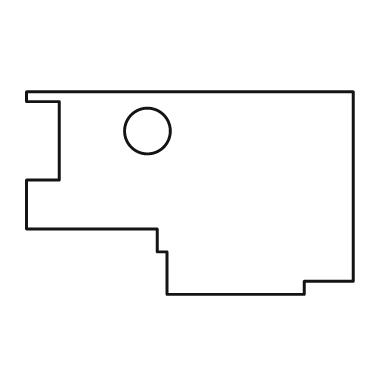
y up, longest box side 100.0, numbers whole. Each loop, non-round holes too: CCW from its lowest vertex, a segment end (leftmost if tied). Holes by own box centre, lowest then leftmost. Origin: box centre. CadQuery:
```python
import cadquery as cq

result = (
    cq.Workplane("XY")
    .moveTo(-7.0, -31.0)
    .lineTo(35.0, -31.0)
    .lineTo(35.0, -27.0)
    .lineTo(50.0, -27.0)
    .lineTo(50.0, 31.0)
    .lineTo(-50.0, 31.0)
    .lineTo(-50.0, 28.0)
    .lineTo(-40.0, 28.0)
    .lineTo(-40.0, 4.0)
    .lineTo(-50.0, 4.0)
    .lineTo(-50.0, -11.0)
    .lineTo(-10.0, -11.0)
    .lineTo(-10.0, -18.0)
    .lineTo(-7.0, -18.0)
    .close()
    .moveTo(-13.0, 19.0)
    .circle(7.0)
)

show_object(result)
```